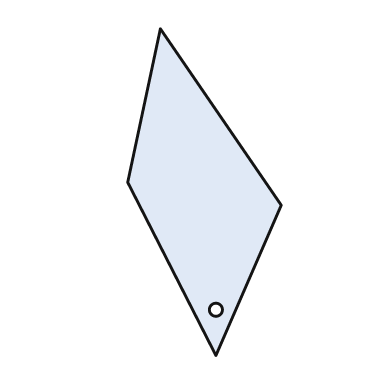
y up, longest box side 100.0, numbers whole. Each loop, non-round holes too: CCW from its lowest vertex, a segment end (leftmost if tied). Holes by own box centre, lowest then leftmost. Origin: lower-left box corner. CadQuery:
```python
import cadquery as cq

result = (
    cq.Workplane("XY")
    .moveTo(27.0, 0.0)
    .lineTo(47.0, 46.0)
    .lineTo(10.0, 100.0)
    .lineTo(0.0, 53.0)
    .close()
    .moveTo(27.0, 14.0)
    .circle(2.0)
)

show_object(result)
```